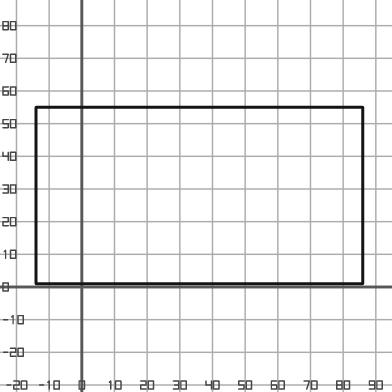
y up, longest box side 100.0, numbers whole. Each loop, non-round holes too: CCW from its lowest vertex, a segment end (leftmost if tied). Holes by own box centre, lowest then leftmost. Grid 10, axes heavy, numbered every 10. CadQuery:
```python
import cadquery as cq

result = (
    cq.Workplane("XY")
    .moveTo(-14.0, 1.0)
    .lineTo(86.0, 1.0)
    .lineTo(86.0, 55.0)
    .lineTo(-14.0, 55.0)
    .close()
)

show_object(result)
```